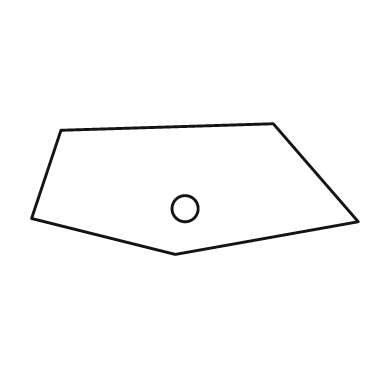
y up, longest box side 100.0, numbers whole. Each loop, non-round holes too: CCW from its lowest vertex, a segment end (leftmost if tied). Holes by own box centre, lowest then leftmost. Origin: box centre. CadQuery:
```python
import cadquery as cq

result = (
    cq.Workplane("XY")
    .moveTo(-6.0, -20.0)
    .lineTo(50.0, -10.0)
    .lineTo(24.0, 20.0)
    .lineTo(-41.0, 18.0)
    .lineTo(-50.0, -9.0)
    .close()
    .moveTo(-3.0, -6.0)
    .circle(4.0)
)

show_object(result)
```